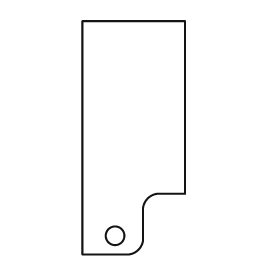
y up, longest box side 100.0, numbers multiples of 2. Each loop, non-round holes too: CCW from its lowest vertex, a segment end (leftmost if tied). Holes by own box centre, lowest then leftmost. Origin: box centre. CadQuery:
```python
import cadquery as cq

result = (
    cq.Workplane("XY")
    .moveTo(-22.0, -50.0)
    .lineTo(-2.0, -50.0)
    .threePointArc((2.0, -48.0), (4.0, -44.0))
    .lineTo(4.0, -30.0)
    .threePointArc((6.0, -26.0), (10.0, -24.0))
    .lineTo(22.0, -24.0)
    .lineTo(22.0, 50.0)
    .lineTo(-22.0, 50.0)
    .close()
    .moveTo(-8.0, -42.0)
    .circle(4.0)
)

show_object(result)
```